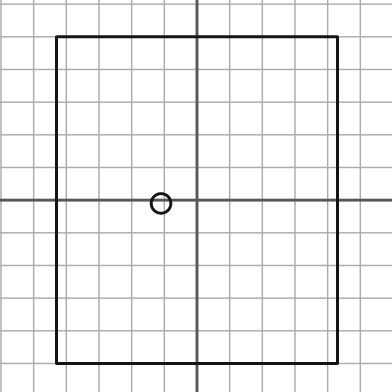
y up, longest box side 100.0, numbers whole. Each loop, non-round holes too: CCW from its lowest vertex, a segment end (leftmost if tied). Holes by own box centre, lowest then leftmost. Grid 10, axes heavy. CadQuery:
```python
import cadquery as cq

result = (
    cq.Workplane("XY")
    .moveTo(-43.0, -50.0)
    .lineTo(43.0, -50.0)
    .lineTo(43.0, 50.0)
    .lineTo(-43.0, 50.0)
    .close()
    .moveTo(-11.0, -1.0)
    .circle(3.0)
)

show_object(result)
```